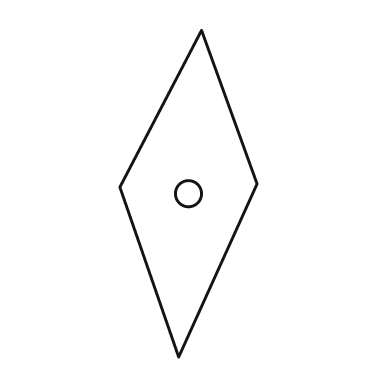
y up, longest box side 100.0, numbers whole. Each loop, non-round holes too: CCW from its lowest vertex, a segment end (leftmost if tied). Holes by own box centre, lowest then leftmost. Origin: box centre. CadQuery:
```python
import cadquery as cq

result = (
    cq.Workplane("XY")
    .moveTo(-3.0, -50.0)
    .lineTo(21.0, 3.0)
    .lineTo(4.0, 50.0)
    .lineTo(-21.0, 2.0)
    .close()
    .moveTo(0.0, 0.0)
    .circle(4.0)
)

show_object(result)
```